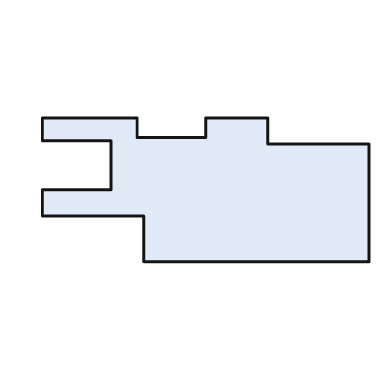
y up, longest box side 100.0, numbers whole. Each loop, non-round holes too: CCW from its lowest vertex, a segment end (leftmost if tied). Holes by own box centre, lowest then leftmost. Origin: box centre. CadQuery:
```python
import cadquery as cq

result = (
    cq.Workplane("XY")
    .moveTo(-19.0, -22.0)
    .lineTo(50.0, -22.0)
    .lineTo(50.0, 14.0)
    .lineTo(19.0, 14.0)
    .lineTo(19.0, 22.0)
    .lineTo(0.0, 22.0)
    .lineTo(0.0, 16.0)
    .lineTo(-21.0, 16.0)
    .lineTo(-21.0, 22.0)
    .lineTo(-50.0, 22.0)
    .lineTo(-50.0, 15.0)
    .lineTo(-29.0, 15.0)
    .lineTo(-29.0, 0.0)
    .lineTo(-50.0, 0.0)
    .lineTo(-50.0, -8.0)
    .lineTo(-19.0, -8.0)
    .close()
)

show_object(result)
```